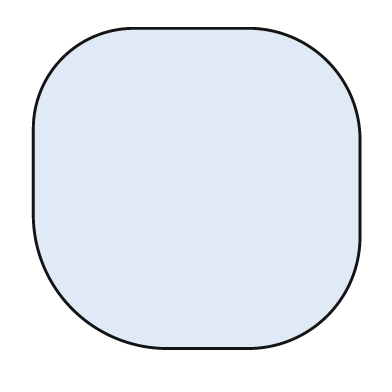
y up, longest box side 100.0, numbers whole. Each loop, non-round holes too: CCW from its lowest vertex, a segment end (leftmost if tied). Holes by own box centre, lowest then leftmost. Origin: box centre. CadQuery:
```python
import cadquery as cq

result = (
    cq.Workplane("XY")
    .moveTo(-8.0, -49.0)
    .lineTo(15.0, -49.0)
    .threePointArc((40.0, -39.0), (50.0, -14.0))
    .lineTo(50.0, 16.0)
    .threePointArc((40.0, 39.0), (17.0, 49.0))
    .lineTo(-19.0, 49.0)
    .threePointArc((-41.0, 40.0), (-50.0, 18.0))
    .lineTo(-50.0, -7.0)
    .threePointArc((-38.0, -37.0), (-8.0, -49.0))
    .close()
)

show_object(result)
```